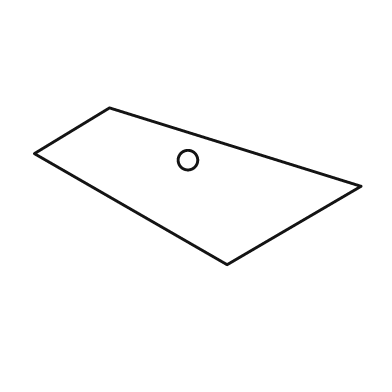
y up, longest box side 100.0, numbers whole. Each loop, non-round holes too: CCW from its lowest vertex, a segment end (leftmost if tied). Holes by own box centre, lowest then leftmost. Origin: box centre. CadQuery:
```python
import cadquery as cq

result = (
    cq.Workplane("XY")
    .moveTo(9.0, -24.0)
    .lineTo(50.0, 0.0)
    .lineTo(-27.0, 24.0)
    .lineTo(-50.0, 10.0)
    .close()
    .moveTo(-3.0, 8.0)
    .circle(3.0)
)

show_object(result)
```